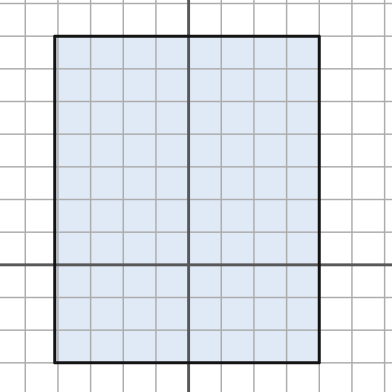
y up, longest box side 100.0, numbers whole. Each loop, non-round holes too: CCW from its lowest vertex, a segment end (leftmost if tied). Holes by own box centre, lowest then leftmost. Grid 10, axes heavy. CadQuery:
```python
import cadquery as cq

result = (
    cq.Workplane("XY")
    .moveTo(-41.0, -30.0)
    .lineTo(40.0, -30.0)
    .lineTo(40.0, 70.0)
    .lineTo(-41.0, 70.0)
    .close()
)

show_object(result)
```